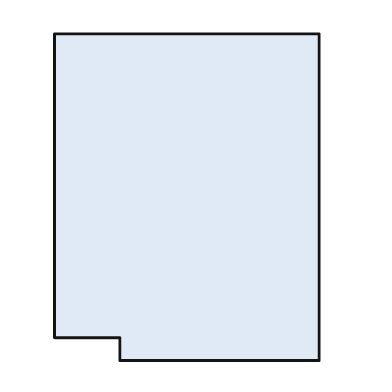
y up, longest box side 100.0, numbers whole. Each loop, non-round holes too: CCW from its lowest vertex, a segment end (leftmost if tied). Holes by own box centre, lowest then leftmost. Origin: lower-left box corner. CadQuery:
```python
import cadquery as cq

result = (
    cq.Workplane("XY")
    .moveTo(20.0, 0.0)
    .lineTo(81.0, 0.0)
    .lineTo(81.0, 100.0)
    .lineTo(0.0, 100.0)
    .lineTo(0.0, 7.0)
    .lineTo(20.0, 7.0)
    .close()
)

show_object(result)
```